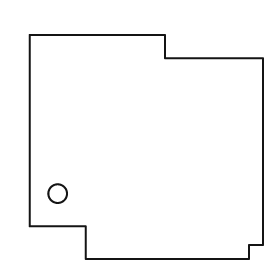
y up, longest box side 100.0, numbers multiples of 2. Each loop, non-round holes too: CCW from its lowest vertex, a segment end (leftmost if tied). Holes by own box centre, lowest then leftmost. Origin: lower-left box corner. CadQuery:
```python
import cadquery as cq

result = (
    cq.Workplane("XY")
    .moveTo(24.0, 0.0)
    .lineTo(94.0, 0.0)
    .lineTo(94.0, 6.0)
    .lineTo(100.0, 6.0)
    .lineTo(100.0, 86.0)
    .lineTo(58.0, 86.0)
    .lineTo(58.0, 96.0)
    .lineTo(0.0, 96.0)
    .lineTo(0.0, 14.0)
    .lineTo(24.0, 14.0)
    .close()
    .moveTo(12.0, 28.0)
    .circle(4.0)
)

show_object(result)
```